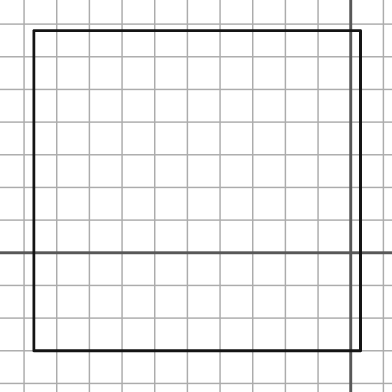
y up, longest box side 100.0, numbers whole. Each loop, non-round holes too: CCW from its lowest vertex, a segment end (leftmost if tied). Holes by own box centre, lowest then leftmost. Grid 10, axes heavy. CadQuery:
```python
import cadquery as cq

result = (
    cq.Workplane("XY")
    .moveTo(-97.0, -30.0)
    .lineTo(3.0, -30.0)
    .lineTo(3.0, 68.0)
    .lineTo(-97.0, 68.0)
    .close()
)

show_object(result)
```